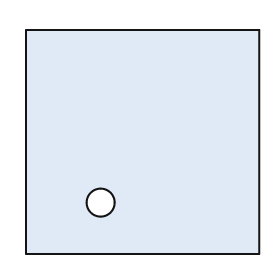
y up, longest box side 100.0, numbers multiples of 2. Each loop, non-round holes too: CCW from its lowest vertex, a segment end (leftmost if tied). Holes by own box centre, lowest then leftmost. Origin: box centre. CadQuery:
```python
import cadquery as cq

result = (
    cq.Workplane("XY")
    .moveTo(-50.0, -48.0)
    .lineTo(50.0, -48.0)
    .lineTo(50.0, 48.0)
    .lineTo(-50.0, 48.0)
    .close()
    .moveTo(-18.0, -26.0)
    .circle(6.0)
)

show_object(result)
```